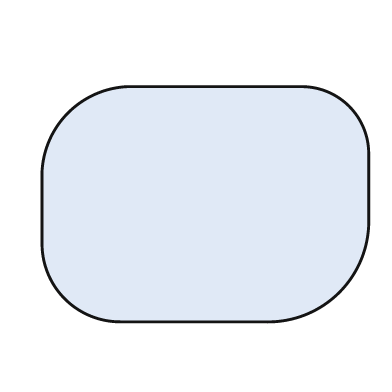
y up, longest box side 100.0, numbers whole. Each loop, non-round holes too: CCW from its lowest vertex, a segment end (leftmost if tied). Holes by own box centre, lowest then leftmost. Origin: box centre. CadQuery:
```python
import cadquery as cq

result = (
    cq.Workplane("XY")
    .moveTo(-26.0, -36.0)
    .lineTo(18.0, -36.0)
    .threePointArc((41.0, -27.0), (50.0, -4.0))
    .lineTo(50.0, 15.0)
    .threePointArc((44.0, 30.0), (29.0, 36.0))
    .lineTo(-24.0, 36.0)
    .threePointArc((-42.0, 28.0), (-50.0, 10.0))
    .lineTo(-50.0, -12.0)
    .threePointArc((-43.0, -29.0), (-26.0, -36.0))
    .close()
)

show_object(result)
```